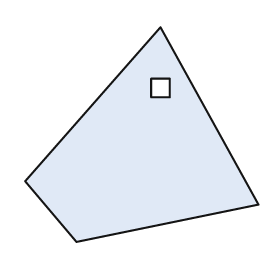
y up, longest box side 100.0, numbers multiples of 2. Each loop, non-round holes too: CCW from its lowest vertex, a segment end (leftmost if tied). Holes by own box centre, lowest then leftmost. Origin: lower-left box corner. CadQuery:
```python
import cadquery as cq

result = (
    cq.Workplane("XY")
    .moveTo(22.0, 0.0)
    .lineTo(100.0, 16.0)
    .lineTo(58.0, 92.0)
    .lineTo(0.0, 26.0)
    .close()
    .moveTo(54.0, 62.0)
    .lineTo(62.0, 62.0)
    .lineTo(62.0, 70.0)
    .lineTo(54.0, 70.0)
    .close()
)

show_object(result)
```